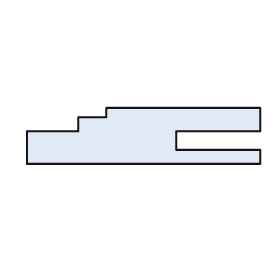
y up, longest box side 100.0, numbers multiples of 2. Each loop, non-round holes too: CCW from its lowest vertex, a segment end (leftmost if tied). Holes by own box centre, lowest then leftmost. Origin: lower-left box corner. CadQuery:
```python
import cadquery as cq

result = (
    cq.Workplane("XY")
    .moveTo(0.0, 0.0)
    .lineTo(100.0, 0.0)
    .lineTo(100.0, 6.0)
    .lineTo(64.0, 6.0)
    .lineTo(64.0, 14.0)
    .lineTo(100.0, 14.0)
    .lineTo(100.0, 24.0)
    .lineTo(34.0, 24.0)
    .lineTo(34.0, 20.0)
    .lineTo(22.0, 20.0)
    .lineTo(22.0, 14.0)
    .lineTo(0.0, 14.0)
    .close()
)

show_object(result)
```